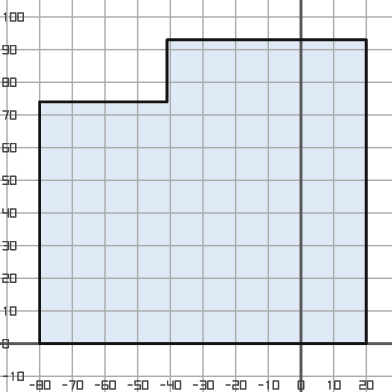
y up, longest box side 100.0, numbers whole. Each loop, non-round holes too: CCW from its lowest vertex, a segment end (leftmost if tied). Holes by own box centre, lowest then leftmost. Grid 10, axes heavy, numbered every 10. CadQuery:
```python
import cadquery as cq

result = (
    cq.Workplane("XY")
    .moveTo(-80.0, 0.0)
    .lineTo(20.0, 0.0)
    .lineTo(20.0, 93.0)
    .lineTo(-41.0, 93.0)
    .lineTo(-41.0, 74.0)
    .lineTo(-80.0, 74.0)
    .close()
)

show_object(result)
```